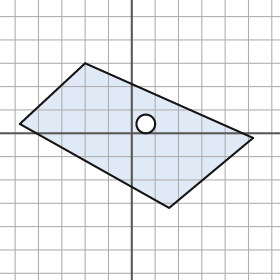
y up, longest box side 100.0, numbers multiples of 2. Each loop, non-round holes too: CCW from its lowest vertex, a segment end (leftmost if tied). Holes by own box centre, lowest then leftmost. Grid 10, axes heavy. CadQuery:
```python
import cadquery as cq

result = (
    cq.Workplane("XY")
    .moveTo(16.0, -32.0)
    .lineTo(52.0, -2.0)
    .lineTo(-20.0, 30.0)
    .lineTo(-48.0, 4.0)
    .close()
    .moveTo(6.0, 4.0)
    .circle(4.0)
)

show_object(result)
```